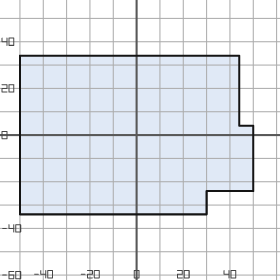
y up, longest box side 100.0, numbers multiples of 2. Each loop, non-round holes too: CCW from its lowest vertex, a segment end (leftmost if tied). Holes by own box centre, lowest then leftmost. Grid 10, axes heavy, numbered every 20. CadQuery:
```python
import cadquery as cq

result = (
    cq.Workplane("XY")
    .moveTo(-50.0, -34.0)
    .lineTo(30.0, -34.0)
    .lineTo(30.0, -24.0)
    .lineTo(50.0, -24.0)
    .lineTo(50.0, 4.0)
    .lineTo(44.0, 4.0)
    .lineTo(44.0, 34.0)
    .lineTo(-50.0, 34.0)
    .close()
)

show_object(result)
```